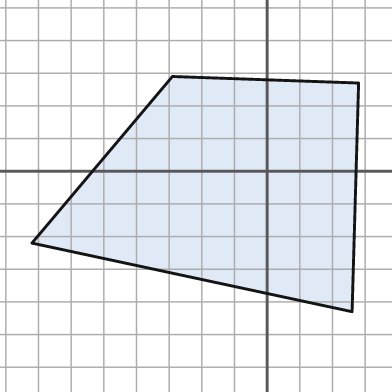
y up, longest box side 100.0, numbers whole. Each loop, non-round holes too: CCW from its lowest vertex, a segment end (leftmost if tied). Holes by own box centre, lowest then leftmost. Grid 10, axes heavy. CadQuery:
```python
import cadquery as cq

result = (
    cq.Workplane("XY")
    .moveTo(26.0, -43.0)
    .lineTo(28.0, 27.0)
    .lineTo(-29.0, 29.0)
    .lineTo(-72.0, -22.0)
    .close()
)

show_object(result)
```